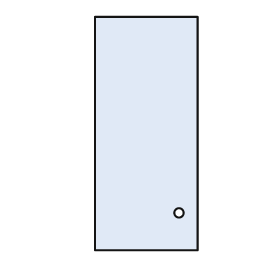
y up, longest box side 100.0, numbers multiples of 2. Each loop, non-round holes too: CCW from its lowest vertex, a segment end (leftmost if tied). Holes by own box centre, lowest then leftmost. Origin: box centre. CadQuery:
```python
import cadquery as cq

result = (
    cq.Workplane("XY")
    .moveTo(-22.0, -50.0)
    .lineTo(22.0, -50.0)
    .lineTo(22.0, 50.0)
    .lineTo(-22.0, 50.0)
    .close()
    .moveTo(14.0, -34.0)
    .circle(2.0)
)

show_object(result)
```